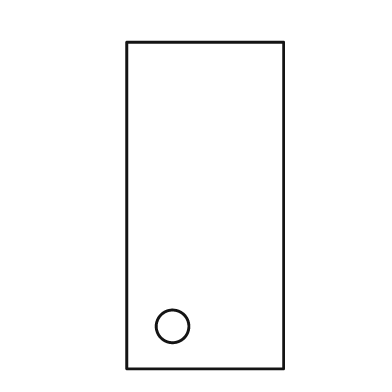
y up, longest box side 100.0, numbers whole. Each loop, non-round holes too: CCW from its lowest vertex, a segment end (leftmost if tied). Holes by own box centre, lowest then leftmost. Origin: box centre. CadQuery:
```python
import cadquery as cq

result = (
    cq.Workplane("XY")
    .moveTo(-24.0, -50.0)
    .lineTo(24.0, -50.0)
    .lineTo(24.0, 50.0)
    .lineTo(-24.0, 50.0)
    .close()
    .moveTo(-10.0, -37.0)
    .circle(5.0)
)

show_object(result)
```